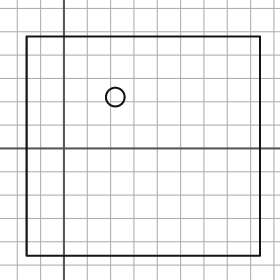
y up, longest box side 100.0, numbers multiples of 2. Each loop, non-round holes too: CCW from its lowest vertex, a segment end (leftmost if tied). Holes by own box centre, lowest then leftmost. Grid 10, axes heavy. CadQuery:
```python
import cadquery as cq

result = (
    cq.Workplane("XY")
    .moveTo(-16.0, -46.0)
    .lineTo(84.0, -46.0)
    .lineTo(84.0, 48.0)
    .lineTo(-16.0, 48.0)
    .close()
    .moveTo(22.0, 22.0)
    .circle(4.0)
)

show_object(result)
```